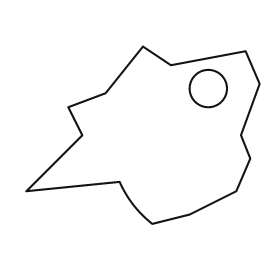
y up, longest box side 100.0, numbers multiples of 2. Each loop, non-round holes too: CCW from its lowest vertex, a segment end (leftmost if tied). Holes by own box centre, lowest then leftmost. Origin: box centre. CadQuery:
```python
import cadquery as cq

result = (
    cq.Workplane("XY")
    .moveTo(4.0, -38.0)
    .lineTo(20.0, -34.0)
    .lineTo(40.0, -24.0)
    .lineTo(46.0, -10.0)
    .lineTo(42.0, 0.0)
    .lineTo(50.0, 22.0)
    .lineTo(44.0, 36.0)
    .lineTo(12.0, 30.0)
    .lineTo(0.0, 38.0)
    .lineTo(-16.0, 18.0)
    .lineTo(-32.0, 12.0)
    .lineTo(-26.0, 0.0)
    .lineTo(-50.0, -24.0)
    .lineTo(-10.0, -20.0)
    .threePointArc((-4.0, -30.0), (4.0, -38.0))
    .close()
    .moveTo(28.0, 20.0)
    .circle(8.0)
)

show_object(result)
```